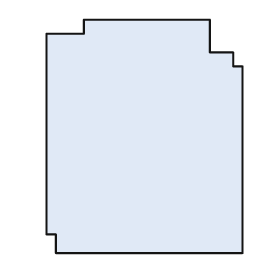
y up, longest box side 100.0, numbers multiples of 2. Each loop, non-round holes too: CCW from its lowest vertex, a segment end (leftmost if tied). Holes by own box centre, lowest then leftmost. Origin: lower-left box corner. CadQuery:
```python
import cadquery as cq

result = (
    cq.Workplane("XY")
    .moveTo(4.0, 0.0)
    .lineTo(84.0, 0.0)
    .lineTo(84.0, 80.0)
    .lineTo(80.0, 80.0)
    .lineTo(80.0, 86.0)
    .lineTo(70.0, 86.0)
    .lineTo(70.0, 100.0)
    .lineTo(16.0, 100.0)
    .lineTo(16.0, 94.0)
    .lineTo(0.0, 94.0)
    .lineTo(0.0, 8.0)
    .lineTo(4.0, 8.0)
    .close()
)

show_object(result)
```